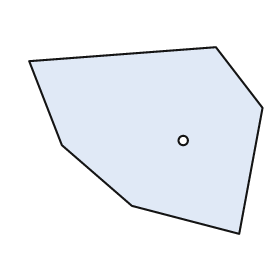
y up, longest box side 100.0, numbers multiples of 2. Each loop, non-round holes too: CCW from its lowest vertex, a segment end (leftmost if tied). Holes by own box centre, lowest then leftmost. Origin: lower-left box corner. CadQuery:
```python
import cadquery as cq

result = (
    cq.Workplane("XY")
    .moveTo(90.0, 0.0)
    .lineTo(100.0, 54.0)
    .lineTo(80.0, 80.0)
    .lineTo(0.0, 74.0)
    .lineTo(14.0, 38.0)
    .lineTo(44.0, 12.0)
    .close()
    .moveTo(66.0, 40.0)
    .circle(2.0)
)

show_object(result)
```